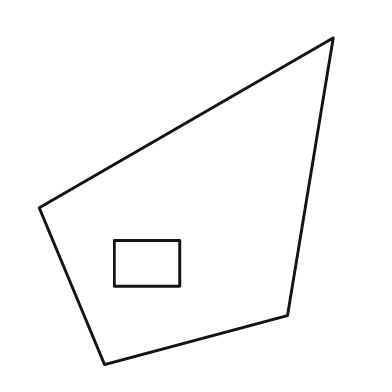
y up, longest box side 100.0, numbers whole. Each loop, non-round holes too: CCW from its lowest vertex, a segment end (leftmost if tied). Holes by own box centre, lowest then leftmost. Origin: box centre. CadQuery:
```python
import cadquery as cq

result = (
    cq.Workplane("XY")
    .moveTo(-25.0, -50.0)
    .lineTo(31.0, -35.0)
    .lineTo(45.0, 50.0)
    .lineTo(-45.0, -2.0)
    .close()
    .moveTo(-22.0, -26.0)
    .lineTo(-2.0, -26.0)
    .lineTo(-2.0, -12.0)
    .lineTo(-22.0, -12.0)
    .close()
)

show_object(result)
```